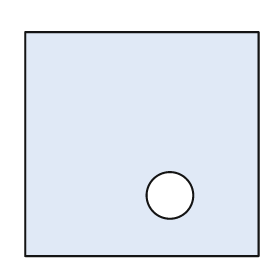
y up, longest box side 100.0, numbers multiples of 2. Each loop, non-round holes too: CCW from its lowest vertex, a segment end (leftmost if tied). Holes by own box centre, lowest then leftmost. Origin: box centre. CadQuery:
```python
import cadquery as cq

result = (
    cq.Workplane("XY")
    .moveTo(-50.0, -48.0)
    .lineTo(50.0, -48.0)
    .lineTo(50.0, 48.0)
    .lineTo(-50.0, 48.0)
    .close()
    .moveTo(12.0, -22.0)
    .circle(10.0)
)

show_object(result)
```